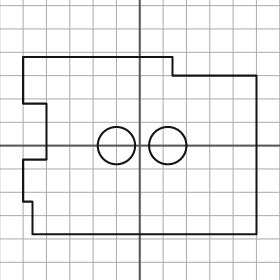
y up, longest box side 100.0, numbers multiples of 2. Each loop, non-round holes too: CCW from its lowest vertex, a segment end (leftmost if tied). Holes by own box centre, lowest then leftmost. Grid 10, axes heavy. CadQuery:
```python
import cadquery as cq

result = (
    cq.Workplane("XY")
    .moveTo(-46.0, -38.0)
    .lineTo(50.0, -38.0)
    .lineTo(50.0, 30.0)
    .lineTo(14.0, 30.0)
    .lineTo(14.0, 38.0)
    .lineTo(-50.0, 38.0)
    .lineTo(-50.0, 18.0)
    .lineTo(-40.0, 18.0)
    .lineTo(-40.0, -6.0)
    .lineTo(-50.0, -6.0)
    .lineTo(-50.0, -24.0)
    .lineTo(-46.0, -24.0)
    .close()
    .moveTo(-10.0, 0.0)
    .circle(8.0)
    .moveTo(12.0, 0.0)
    .circle(8.0)
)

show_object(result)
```